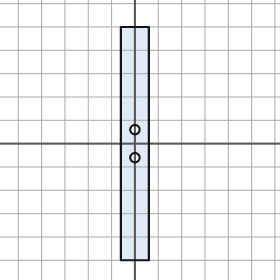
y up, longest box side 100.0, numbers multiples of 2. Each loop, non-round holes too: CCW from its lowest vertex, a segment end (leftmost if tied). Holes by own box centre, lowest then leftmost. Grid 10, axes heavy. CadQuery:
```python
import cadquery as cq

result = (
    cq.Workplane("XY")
    .moveTo(-6.0, -50.0)
    .lineTo(6.0, -50.0)
    .lineTo(6.0, 50.0)
    .lineTo(-6.0, 50.0)
    .close()
    .moveTo(0.0, -6.0)
    .circle(2.0)
    .moveTo(0.0, 6.0)
    .circle(2.0)
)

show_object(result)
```